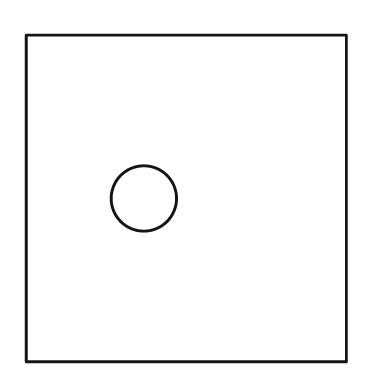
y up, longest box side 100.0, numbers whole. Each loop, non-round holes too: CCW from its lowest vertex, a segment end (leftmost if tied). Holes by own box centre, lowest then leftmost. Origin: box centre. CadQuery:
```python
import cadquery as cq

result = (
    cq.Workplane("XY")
    .moveTo(-49.0, -50.0)
    .lineTo(49.0, -50.0)
    .lineTo(49.0, 50.0)
    .lineTo(-49.0, 50.0)
    .close()
    .moveTo(-13.0, 0.0)
    .circle(10.0)
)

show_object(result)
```